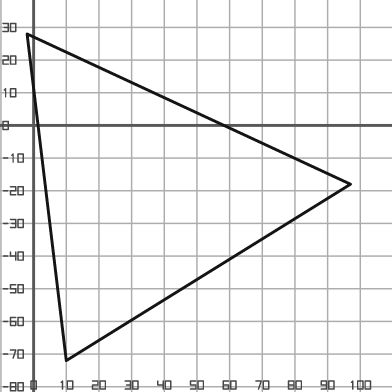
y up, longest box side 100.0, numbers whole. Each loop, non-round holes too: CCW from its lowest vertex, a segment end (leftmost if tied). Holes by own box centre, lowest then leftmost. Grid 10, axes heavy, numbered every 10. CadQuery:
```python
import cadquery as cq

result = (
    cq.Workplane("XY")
    .moveTo(10.0, -72.0)
    .lineTo(97.0, -18.0)
    .lineTo(-2.0, 28.0)
    .close()
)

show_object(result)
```